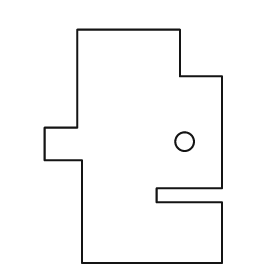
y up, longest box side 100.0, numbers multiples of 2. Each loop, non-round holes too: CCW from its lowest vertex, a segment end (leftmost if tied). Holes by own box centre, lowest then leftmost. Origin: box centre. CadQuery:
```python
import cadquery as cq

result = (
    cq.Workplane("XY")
    .moveTo(-22.0, -50.0)
    .lineTo(38.0, -50.0)
    .lineTo(38.0, -24.0)
    .lineTo(10.0, -24.0)
    .lineTo(10.0, -18.0)
    .lineTo(38.0, -18.0)
    .lineTo(38.0, 30.0)
    .lineTo(20.0, 30.0)
    .lineTo(20.0, 50.0)
    .lineTo(-24.0, 50.0)
    .lineTo(-24.0, 8.0)
    .lineTo(-38.0, 8.0)
    .lineTo(-38.0, -6.0)
    .lineTo(-22.0, -6.0)
    .close()
    .moveTo(22.0, 2.0)
    .circle(4.0)
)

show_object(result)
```